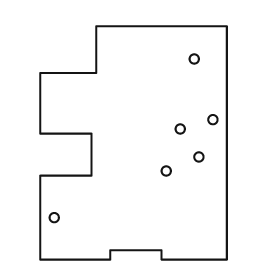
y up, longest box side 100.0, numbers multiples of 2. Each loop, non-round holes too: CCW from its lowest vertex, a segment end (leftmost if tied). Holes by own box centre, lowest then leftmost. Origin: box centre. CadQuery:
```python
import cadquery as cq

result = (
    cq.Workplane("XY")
    .moveTo(-40.0, -50.0)
    .lineTo(-10.0, -50.0)
    .lineTo(-10.0, -46.0)
    .lineTo(12.0, -46.0)
    .lineTo(12.0, -50.0)
    .lineTo(40.0, -50.0)
    .lineTo(40.0, 50.0)
    .lineTo(-16.0, 50.0)
    .lineTo(-16.0, 30.0)
    .lineTo(-40.0, 30.0)
    .lineTo(-40.0, 4.0)
    .lineTo(-18.0, 4.0)
    .lineTo(-18.0, -14.0)
    .lineTo(-40.0, -14.0)
    .close()
    .moveTo(-34.0, -32.0)
    .circle(2.0)
    .moveTo(14.0, -12.0)
    .circle(2.0)
    .moveTo(28.0, -6.0)
    .circle(2.0)
    .moveTo(20.0, 6.0)
    .circle(2.0)
    .moveTo(34.0, 10.0)
    .circle(2.0)
    .moveTo(26.0, 36.0)
    .circle(2.0)
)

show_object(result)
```